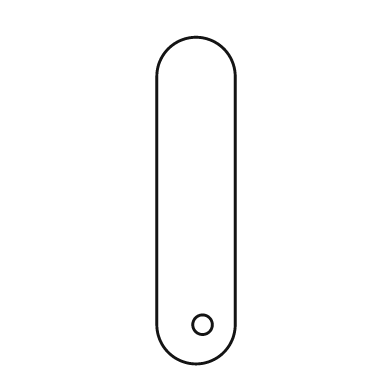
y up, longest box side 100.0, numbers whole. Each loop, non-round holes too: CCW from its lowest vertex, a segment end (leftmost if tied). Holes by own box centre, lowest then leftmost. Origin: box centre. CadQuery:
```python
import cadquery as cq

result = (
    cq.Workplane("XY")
    .moveTo(-12.0, -38.0)
    .threePointArc((0.0, -50.0), (12.0, -38.0))
    .lineTo(12.0, 38.0)
    .threePointArc((0.0, 50.0), (-12.0, 38.0))
    .close()
    .moveTo(2.0, -38.0)
    .circle(3.0)
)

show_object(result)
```